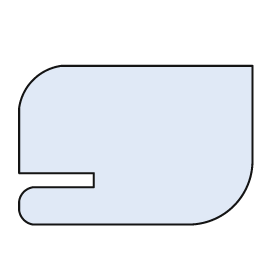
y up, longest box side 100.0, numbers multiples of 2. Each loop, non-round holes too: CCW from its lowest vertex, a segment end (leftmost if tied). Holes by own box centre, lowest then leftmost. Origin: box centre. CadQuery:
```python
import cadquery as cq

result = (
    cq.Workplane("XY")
    .moveTo(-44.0, -34.0)
    .lineTo(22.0, -34.0)
    .threePointArc((42.0, -26.0), (50.0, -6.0))
    .lineTo(50.0, 34.0)
    .lineTo(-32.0, 34.0)
    .threePointArc((-44.0, 28.0), (-50.0, 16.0))
    .lineTo(-50.0, -12.0)
    .lineTo(-18.0, -12.0)
    .lineTo(-18.0, -18.0)
    .lineTo(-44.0, -18.0)
    .threePointArc((-48.0, -20.0), (-50.0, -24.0))
    .lineTo(-50.0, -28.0)
    .threePointArc((-48.0, -32.0), (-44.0, -34.0))
    .close()
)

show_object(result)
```